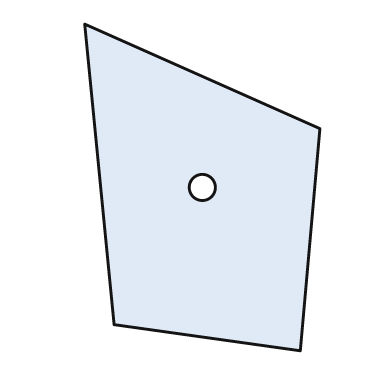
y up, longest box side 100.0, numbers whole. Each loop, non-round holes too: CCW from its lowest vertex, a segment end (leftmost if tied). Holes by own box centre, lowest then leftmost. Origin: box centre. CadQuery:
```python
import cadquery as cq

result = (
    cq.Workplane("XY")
    .moveTo(30.0, -50.0)
    .lineTo(36.0, 18.0)
    .lineTo(-36.0, 50.0)
    .lineTo(-27.0, -42.0)
    .close()
    .moveTo(0.0, 0.0)
    .circle(4.0)
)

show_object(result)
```